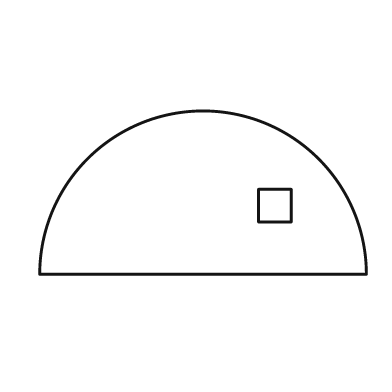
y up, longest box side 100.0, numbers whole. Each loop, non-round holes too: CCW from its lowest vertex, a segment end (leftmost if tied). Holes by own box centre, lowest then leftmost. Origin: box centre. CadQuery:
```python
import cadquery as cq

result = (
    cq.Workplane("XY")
    .moveTo(-50.0, -25.0)
    .lineTo(50.0, -25.0)
    .threePointArc((0.0, 25.0), (-50.0, -25.0))
    .close()
    .moveTo(17.0, -9.0)
    .lineTo(27.0, -9.0)
    .lineTo(27.0, 1.0)
    .lineTo(17.0, 1.0)
    .close()
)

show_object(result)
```